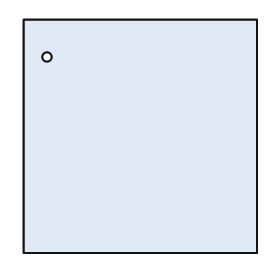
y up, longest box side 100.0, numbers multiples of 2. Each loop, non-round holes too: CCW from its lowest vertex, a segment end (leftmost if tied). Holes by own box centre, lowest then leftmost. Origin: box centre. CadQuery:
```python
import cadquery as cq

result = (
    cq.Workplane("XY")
    .moveTo(-50.0, -50.0)
    .lineTo(50.0, -50.0)
    .lineTo(50.0, 50.0)
    .lineTo(-50.0, 50.0)
    .close()
    .moveTo(-40.0, 34.0)
    .circle(2.0)
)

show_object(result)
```